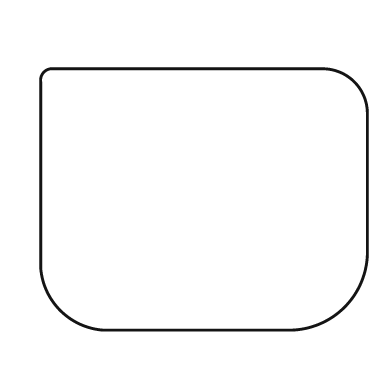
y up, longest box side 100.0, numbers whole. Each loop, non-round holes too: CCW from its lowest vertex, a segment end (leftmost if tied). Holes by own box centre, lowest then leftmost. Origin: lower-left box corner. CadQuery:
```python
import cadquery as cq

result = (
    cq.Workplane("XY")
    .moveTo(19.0, 0.0)
    .lineTo(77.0, 0.0)
    .threePointArc((93.0, 7.0), (100.0, 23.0))
    .lineTo(100.0, 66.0)
    .threePointArc((96.0, 76.0), (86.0, 80.0))
    .lineTo(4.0, 80.0)
    .threePointArc((1.0, 79.0), (0.0, 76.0))
    .lineTo(0.0, 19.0)
    .threePointArc((6.0, 6.0), (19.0, 0.0))
    .close()
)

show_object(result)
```